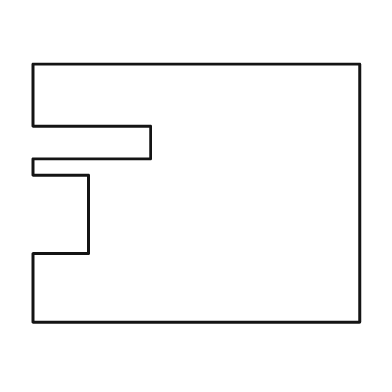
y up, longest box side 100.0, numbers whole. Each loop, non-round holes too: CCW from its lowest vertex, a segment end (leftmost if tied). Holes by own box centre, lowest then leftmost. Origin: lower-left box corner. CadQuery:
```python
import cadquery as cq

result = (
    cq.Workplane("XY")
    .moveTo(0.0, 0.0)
    .lineTo(100.0, 0.0)
    .lineTo(100.0, 79.0)
    .lineTo(0.0, 79.0)
    .lineTo(0.0, 60.0)
    .lineTo(36.0, 60.0)
    .lineTo(36.0, 50.0)
    .lineTo(0.0, 50.0)
    .lineTo(0.0, 45.0)
    .lineTo(17.0, 45.0)
    .lineTo(17.0, 21.0)
    .lineTo(0.0, 21.0)
    .close()
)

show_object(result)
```